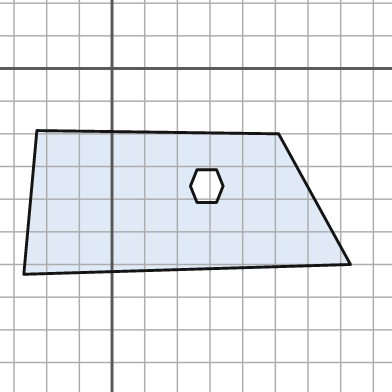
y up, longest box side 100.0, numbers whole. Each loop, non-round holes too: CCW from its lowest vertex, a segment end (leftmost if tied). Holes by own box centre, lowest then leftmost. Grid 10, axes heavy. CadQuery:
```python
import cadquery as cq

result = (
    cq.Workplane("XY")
    .moveTo(-27.0, -63.0)
    .lineTo(73.0, -60.0)
    .lineTo(51.0, -20.0)
    .lineTo(-23.0, -19.0)
    .close()
    .moveTo(26.0, -41.0)
    .lineTo(32.0, -41.0)
    .lineTo(34.0, -36.0)
    .lineTo(32.0, -31.0)
    .lineTo(26.0, -31.0)
    .lineTo(24.0, -36.0)
    .close()
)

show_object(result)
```